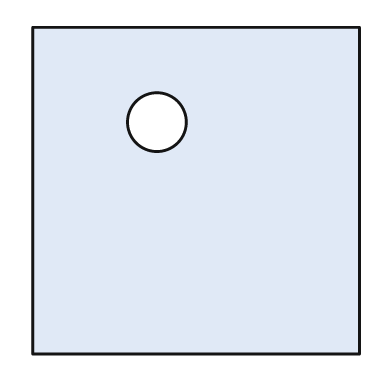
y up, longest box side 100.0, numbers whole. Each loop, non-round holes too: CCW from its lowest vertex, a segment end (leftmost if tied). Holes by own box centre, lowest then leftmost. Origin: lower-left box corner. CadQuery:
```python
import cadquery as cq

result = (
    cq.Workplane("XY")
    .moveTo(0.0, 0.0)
    .lineTo(100.0, 0.0)
    .lineTo(100.0, 100.0)
    .lineTo(0.0, 100.0)
    .close()
    .moveTo(38.0, 71.0)
    .circle(9.0)
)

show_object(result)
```